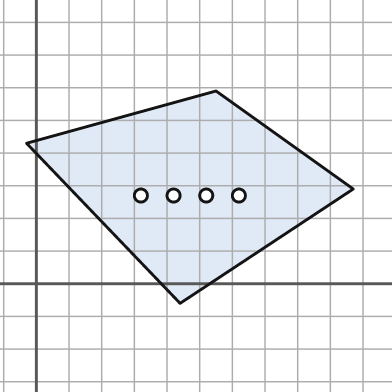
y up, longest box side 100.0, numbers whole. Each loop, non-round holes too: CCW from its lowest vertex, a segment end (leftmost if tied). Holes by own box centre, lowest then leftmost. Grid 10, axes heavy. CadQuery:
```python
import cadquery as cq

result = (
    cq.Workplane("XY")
    .moveTo(44.0, -6.0)
    .lineTo(97.0, 29.0)
    .lineTo(55.0, 59.0)
    .lineTo(-3.0, 43.0)
    .close()
    .moveTo(32.0, 27.0)
    .circle(2.0)
    .moveTo(42.0, 27.0)
    .circle(2.0)
    .moveTo(52.0, 27.0)
    .circle(2.0)
    .moveTo(62.0, 27.0)
    .circle(2.0)
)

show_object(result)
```